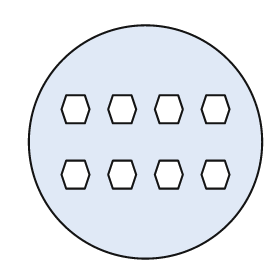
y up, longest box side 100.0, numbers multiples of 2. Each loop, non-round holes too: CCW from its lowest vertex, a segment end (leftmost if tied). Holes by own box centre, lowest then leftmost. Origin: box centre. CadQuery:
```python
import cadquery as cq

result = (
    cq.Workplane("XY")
    .moveTo(0.0, 0.0)
    .circle(50.0)
    .moveTo(-34.0, -20.0)
    .lineTo(-26.0, -20.0)
    .lineTo(-24.0, -14.0)
    .lineTo(-26.0, -8.0)
    .lineTo(-34.0, -8.0)
    .lineTo(-36.0, -14.0)
    .close()
    .moveTo(-14.0, -20.0)
    .lineTo(-6.0, -20.0)
    .lineTo(-4.0, -14.0)
    .lineTo(-6.0, -8.0)
    .lineTo(-14.0, -8.0)
    .lineTo(-16.0, -14.0)
    .close()
    .moveTo(6.0, -20.0)
    .lineTo(14.0, -20.0)
    .lineTo(16.0, -14.0)
    .lineTo(14.0, -8.0)
    .lineTo(6.0, -8.0)
    .lineTo(4.0, -14.0)
    .close()
    .moveTo(26.0, -20.0)
    .lineTo(34.0, -20.0)
    .lineTo(36.0, -14.0)
    .lineTo(34.0, -8.0)
    .lineTo(26.0, -8.0)
    .lineTo(24.0, -14.0)
    .close()
    .moveTo(-34.0, 8.0)
    .lineTo(-26.0, 8.0)
    .lineTo(-24.0, 14.0)
    .lineTo(-26.0, 20.0)
    .lineTo(-34.0, 20.0)
    .lineTo(-36.0, 14.0)
    .close()
    .moveTo(-14.0, 8.0)
    .lineTo(-6.0, 8.0)
    .lineTo(-4.0, 14.0)
    .lineTo(-6.0, 20.0)
    .lineTo(-14.0, 20.0)
    .lineTo(-16.0, 14.0)
    .close()
    .moveTo(6.0, 8.0)
    .lineTo(14.0, 8.0)
    .lineTo(16.0, 14.0)
    .lineTo(14.0, 20.0)
    .lineTo(6.0, 20.0)
    .lineTo(4.0, 14.0)
    .close()
    .moveTo(26.0, 8.0)
    .lineTo(34.0, 8.0)
    .lineTo(36.0, 14.0)
    .lineTo(34.0, 20.0)
    .lineTo(26.0, 20.0)
    .lineTo(24.0, 14.0)
    .close()
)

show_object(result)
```